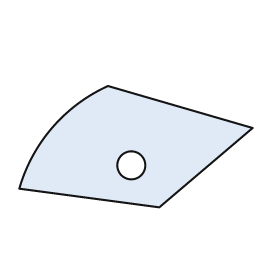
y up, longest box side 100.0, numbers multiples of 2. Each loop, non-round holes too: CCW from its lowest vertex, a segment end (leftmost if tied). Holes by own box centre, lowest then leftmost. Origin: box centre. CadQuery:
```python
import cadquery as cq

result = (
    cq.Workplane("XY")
    .moveTo(10.0, -26.0)
    .lineTo(50.0, 8.0)
    .lineTo(-12.0, 26.0)
    .threePointArc((-36.0, 8.0), (-50.0, -18.0))
    .close()
    .moveTo(-2.0, -8.0)
    .circle(6.0)
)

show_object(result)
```